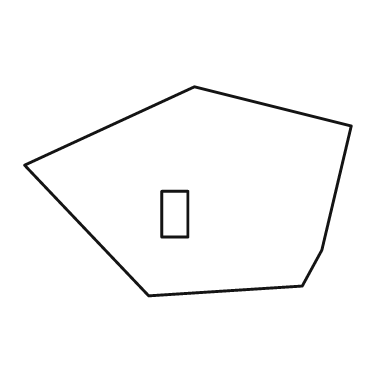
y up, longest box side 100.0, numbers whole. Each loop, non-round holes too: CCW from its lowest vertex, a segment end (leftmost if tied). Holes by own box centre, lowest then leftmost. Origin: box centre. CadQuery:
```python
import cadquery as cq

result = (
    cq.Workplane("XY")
    .moveTo(-12.0, -32.0)
    .lineTo(35.0, -29.0)
    .lineTo(41.0, -18.0)
    .lineTo(50.0, 20.0)
    .lineTo(2.0, 32.0)
    .lineTo(-50.0, 8.0)
    .close()
    .moveTo(-8.0, -14.0)
    .lineTo(0.0, -14.0)
    .lineTo(0.0, 0.0)
    .lineTo(-8.0, 0.0)
    .close()
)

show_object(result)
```